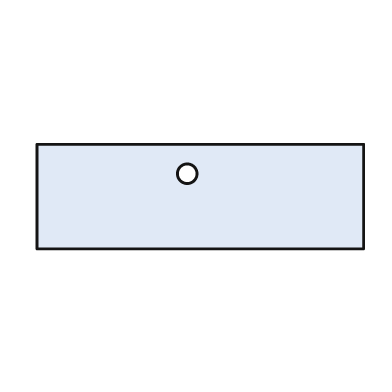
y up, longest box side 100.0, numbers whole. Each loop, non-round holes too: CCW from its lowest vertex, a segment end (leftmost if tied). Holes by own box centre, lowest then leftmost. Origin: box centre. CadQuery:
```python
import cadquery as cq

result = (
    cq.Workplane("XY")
    .moveTo(-50.0, -16.0)
    .lineTo(50.0, -16.0)
    .lineTo(50.0, 16.0)
    .lineTo(-50.0, 16.0)
    .close()
    .moveTo(-4.0, 7.0)
    .circle(3.0)
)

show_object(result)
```